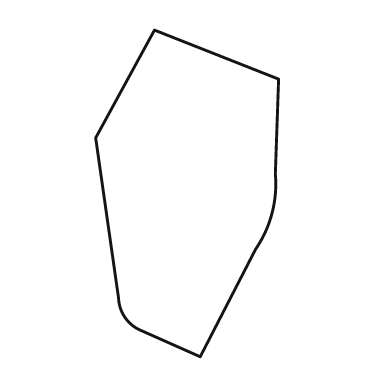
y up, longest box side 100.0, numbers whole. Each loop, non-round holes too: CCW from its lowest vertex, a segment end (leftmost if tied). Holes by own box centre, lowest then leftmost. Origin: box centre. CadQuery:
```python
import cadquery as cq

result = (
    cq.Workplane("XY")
    .moveTo(4.0, -50.0)
    .lineTo(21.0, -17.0)
    .threePointArc((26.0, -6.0), (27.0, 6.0))
    .lineTo(28.0, 35.0)
    .lineTo(-10.0, 50.0)
    .lineTo(-28.0, 17.0)
    .lineTo(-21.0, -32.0)
    .threePointArc((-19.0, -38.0), (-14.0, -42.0))
    .close()
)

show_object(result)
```